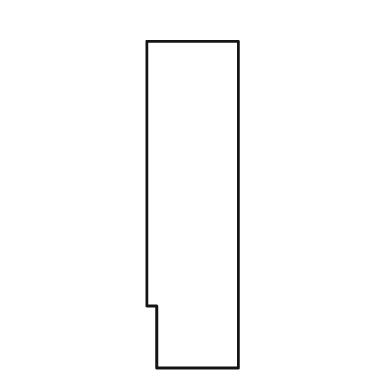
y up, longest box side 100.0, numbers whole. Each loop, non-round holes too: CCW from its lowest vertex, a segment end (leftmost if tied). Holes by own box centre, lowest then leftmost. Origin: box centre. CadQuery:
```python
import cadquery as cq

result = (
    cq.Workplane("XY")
    .moveTo(-11.0, -50.0)
    .lineTo(14.0, -50.0)
    .lineTo(14.0, 50.0)
    .lineTo(-14.0, 50.0)
    .lineTo(-14.0, -31.0)
    .lineTo(-11.0, -31.0)
    .close()
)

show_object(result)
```